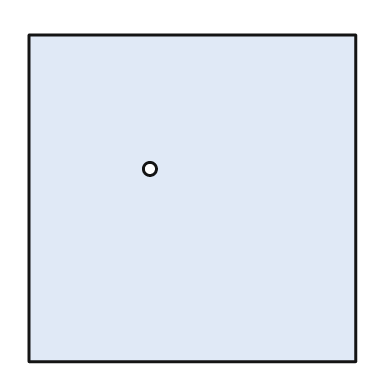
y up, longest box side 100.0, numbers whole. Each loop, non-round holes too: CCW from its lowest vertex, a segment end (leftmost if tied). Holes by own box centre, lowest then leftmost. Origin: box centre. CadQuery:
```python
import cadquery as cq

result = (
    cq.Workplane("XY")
    .moveTo(-50.0, -50.0)
    .lineTo(50.0, -50.0)
    .lineTo(50.0, 50.0)
    .lineTo(-50.0, 50.0)
    .close()
    .moveTo(-13.0, 9.0)
    .circle(2.0)
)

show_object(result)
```